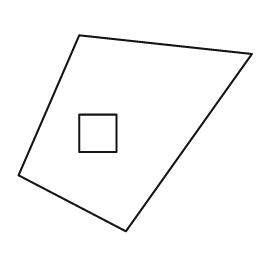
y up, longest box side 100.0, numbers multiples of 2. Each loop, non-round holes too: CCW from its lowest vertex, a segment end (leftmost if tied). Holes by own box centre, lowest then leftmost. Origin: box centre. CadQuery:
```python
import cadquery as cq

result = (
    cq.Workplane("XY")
    .moveTo(-4.0, -42.0)
    .lineTo(50.0, 34.0)
    .lineTo(-24.0, 42.0)
    .lineTo(-50.0, -18.0)
    .close()
    .moveTo(-24.0, -8.0)
    .lineTo(-8.0, -8.0)
    .lineTo(-8.0, 8.0)
    .lineTo(-24.0, 8.0)
    .close()
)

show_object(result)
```